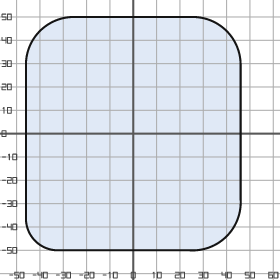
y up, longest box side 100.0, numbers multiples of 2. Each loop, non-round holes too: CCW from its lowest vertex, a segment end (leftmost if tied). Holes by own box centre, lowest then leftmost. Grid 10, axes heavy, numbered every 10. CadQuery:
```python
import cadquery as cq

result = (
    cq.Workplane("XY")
    .moveTo(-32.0, -50.0)
    .lineTo(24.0, -50.0)
    .threePointArc((40.0, -44.0), (46.0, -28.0))
    .lineTo(46.0, 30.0)
    .threePointArc((40.0, 44.0), (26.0, 50.0))
    .lineTo(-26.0, 50.0)
    .threePointArc((-40.0, 44.0), (-46.0, 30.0))
    .lineTo(-46.0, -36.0)
    .threePointArc((-42.0, -46.0), (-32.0, -50.0))
    .close()
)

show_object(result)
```